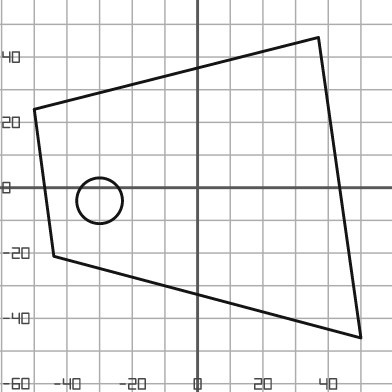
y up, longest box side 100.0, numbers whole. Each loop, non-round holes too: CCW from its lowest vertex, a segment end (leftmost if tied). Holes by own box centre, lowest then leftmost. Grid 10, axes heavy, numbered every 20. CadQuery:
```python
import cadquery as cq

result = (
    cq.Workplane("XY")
    .moveTo(50.0, -46.0)
    .lineTo(37.0, 46.0)
    .lineTo(-50.0, 24.0)
    .lineTo(-44.0, -21.0)
    .close()
    .moveTo(-30.0, -4.0)
    .circle(7.0)
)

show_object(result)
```